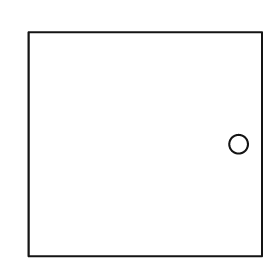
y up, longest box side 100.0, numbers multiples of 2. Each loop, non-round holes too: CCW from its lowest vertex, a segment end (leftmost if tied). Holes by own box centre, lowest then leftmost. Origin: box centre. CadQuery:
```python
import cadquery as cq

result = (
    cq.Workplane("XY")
    .moveTo(-50.0, -48.0)
    .lineTo(50.0, -48.0)
    .lineTo(50.0, 48.0)
    .lineTo(-50.0, 48.0)
    .close()
    .moveTo(40.0, 0.0)
    .circle(4.0)
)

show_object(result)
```